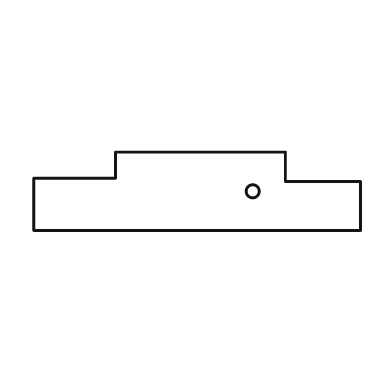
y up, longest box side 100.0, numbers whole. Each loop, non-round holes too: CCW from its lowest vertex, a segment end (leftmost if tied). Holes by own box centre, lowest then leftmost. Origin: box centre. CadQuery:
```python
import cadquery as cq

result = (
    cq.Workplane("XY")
    .moveTo(-50.0, -12.0)
    .lineTo(50.0, -12.0)
    .lineTo(50.0, 3.0)
    .lineTo(27.0, 3.0)
    .lineTo(27.0, 12.0)
    .lineTo(-25.0, 12.0)
    .lineTo(-25.0, 4.0)
    .lineTo(-50.0, 4.0)
    .close()
    .moveTo(17.0, 0.0)
    .circle(2.0)
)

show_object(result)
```